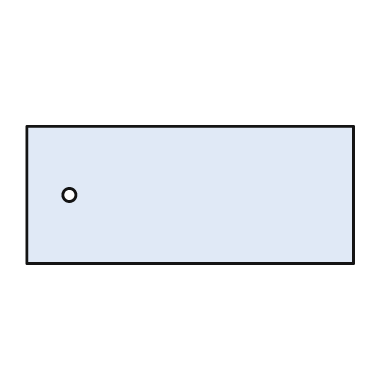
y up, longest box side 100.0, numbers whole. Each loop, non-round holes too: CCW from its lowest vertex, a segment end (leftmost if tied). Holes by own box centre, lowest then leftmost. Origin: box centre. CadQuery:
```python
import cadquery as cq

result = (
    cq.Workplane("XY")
    .moveTo(-50.0, -21.0)
    .lineTo(50.0, -21.0)
    .lineTo(50.0, 21.0)
    .lineTo(-50.0, 21.0)
    .close()
    .moveTo(-37.0, 0.0)
    .circle(2.0)
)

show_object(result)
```